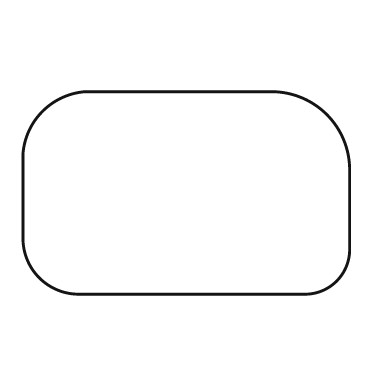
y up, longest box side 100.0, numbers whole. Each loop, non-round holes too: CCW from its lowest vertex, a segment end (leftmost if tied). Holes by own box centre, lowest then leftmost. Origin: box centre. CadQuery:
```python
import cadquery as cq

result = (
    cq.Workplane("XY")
    .moveTo(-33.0, -31.0)
    .lineTo(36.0, -31.0)
    .threePointArc((46.0, -27.0), (50.0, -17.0))
    .lineTo(50.0, 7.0)
    .threePointArc((43.0, 24.0), (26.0, 31.0))
    .lineTo(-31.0, 31.0)
    .threePointArc((-44.0, 25.0), (-50.0, 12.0))
    .lineTo(-50.0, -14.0)
    .threePointArc((-45.0, -26.0), (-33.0, -31.0))
    .close()
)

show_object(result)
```